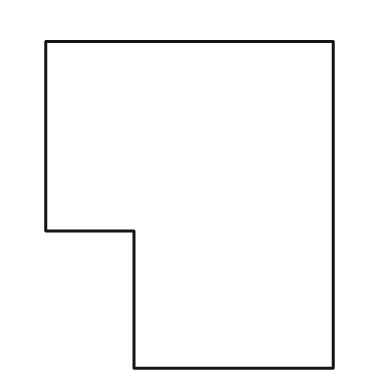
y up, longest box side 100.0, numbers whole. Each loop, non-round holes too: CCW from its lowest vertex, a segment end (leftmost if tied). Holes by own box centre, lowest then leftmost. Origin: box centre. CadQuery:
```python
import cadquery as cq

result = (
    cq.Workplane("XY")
    .moveTo(-17.0, -50.0)
    .lineTo(44.0, -50.0)
    .lineTo(44.0, 50.0)
    .lineTo(-44.0, 50.0)
    .lineTo(-44.0, -8.0)
    .lineTo(-17.0, -8.0)
    .close()
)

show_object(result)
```